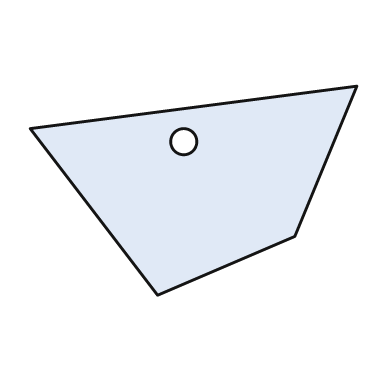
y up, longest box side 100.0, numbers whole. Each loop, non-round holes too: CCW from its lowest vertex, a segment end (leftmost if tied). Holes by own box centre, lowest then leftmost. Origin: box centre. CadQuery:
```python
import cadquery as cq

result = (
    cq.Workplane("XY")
    .moveTo(-11.0, -32.0)
    .lineTo(31.0, -14.0)
    .lineTo(50.0, 32.0)
    .lineTo(-50.0, 19.0)
    .close()
    .moveTo(-3.0, 15.0)
    .circle(4.0)
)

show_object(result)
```